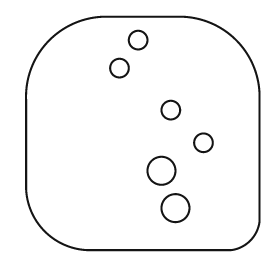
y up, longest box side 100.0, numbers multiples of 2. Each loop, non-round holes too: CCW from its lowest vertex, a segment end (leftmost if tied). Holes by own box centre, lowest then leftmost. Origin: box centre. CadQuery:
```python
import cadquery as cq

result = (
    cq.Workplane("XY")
    .moveTo(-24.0, -50.0)
    .lineTo(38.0, -50.0)
    .threePointArc((46.0, -46.0), (50.0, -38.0))
    .lineTo(50.0, 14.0)
    .threePointArc((40.0, 40.0), (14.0, 50.0))
    .lineTo(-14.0, 50.0)
    .threePointArc((-40.0, 40.0), (-50.0, 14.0))
    .lineTo(-50.0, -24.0)
    .threePointArc((-42.0, -42.0), (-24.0, -50.0))
    .close()
    .moveTo(14.0, -32.0)
    .circle(6.0)
    .moveTo(8.0, -16.0)
    .circle(6.0)
    .moveTo(26.0, -4.0)
    .circle(4.0)
    .moveTo(12.0, 10.0)
    .circle(4.0)
    .moveTo(-10.0, 28.0)
    .circle(4.0)
    .moveTo(-2.0, 40.0)
    .circle(4.0)
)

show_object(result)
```